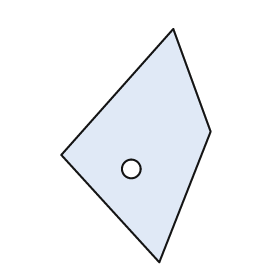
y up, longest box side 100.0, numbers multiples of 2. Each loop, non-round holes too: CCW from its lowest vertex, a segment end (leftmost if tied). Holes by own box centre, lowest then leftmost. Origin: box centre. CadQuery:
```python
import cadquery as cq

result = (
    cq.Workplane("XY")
    .moveTo(10.0, -50.0)
    .lineTo(32.0, 6.0)
    .lineTo(16.0, 50.0)
    .lineTo(-32.0, -4.0)
    .close()
    .moveTo(-2.0, -10.0)
    .circle(4.0)
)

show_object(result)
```